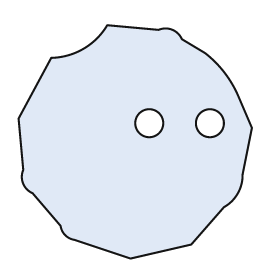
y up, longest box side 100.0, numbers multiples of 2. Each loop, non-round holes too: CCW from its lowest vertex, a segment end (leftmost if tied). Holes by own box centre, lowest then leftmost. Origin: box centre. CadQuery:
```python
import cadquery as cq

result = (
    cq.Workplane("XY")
    .moveTo(-2.0, -50.0)
    .lineTo(24.0, -44.0)
    .lineTo(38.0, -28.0)
    .threePointArc((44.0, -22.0), (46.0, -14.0))
    .lineTo(50.0, 6.0)
    .lineTo(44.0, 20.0)
    .threePointArc((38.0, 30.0), (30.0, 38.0))
    .lineTo(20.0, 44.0)
    .threePointArc((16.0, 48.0), (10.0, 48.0))
    .lineTo(-12.0, 50.0)
    .threePointArc((-22.0, 40.0), (-36.0, 36.0))
    .lineTo(-50.0, 10.0)
    .lineTo(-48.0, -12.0)
    .threePointArc((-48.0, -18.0), (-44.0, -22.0))
    .lineTo(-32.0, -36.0)
    .threePointArc((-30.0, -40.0), (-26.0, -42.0))
    .close()
    .moveTo(6.0, 8.0)
    .circle(6.0)
    .moveTo(32.0, 8.0)
    .circle(6.0)
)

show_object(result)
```